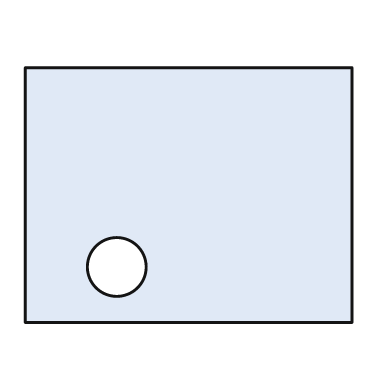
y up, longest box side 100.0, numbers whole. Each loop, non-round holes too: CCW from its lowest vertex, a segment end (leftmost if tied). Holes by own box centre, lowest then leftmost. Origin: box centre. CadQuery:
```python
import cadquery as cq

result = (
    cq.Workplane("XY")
    .moveTo(-50.0, -39.0)
    .lineTo(50.0, -39.0)
    .lineTo(50.0, 39.0)
    .lineTo(-50.0, 39.0)
    .close()
    .moveTo(-22.0, -22.0)
    .circle(9.0)
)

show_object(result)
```